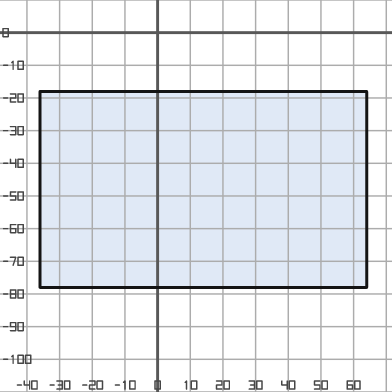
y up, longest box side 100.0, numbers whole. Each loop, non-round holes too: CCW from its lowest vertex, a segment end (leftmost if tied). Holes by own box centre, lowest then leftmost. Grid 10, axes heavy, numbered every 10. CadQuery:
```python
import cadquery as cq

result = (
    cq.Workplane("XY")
    .moveTo(-36.0, -78.0)
    .lineTo(64.0, -78.0)
    .lineTo(64.0, -18.0)
    .lineTo(-36.0, -18.0)
    .close()
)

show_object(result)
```